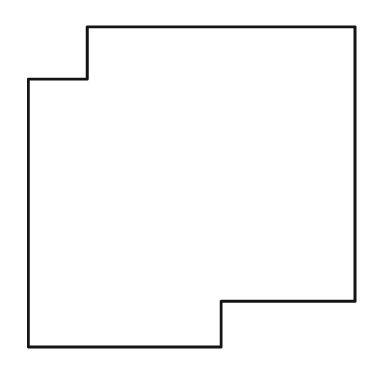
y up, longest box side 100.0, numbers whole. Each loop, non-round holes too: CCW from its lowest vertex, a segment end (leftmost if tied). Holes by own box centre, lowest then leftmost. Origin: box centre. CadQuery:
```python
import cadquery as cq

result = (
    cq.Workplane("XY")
    .moveTo(-50.0, -49.0)
    .lineTo(9.0, -49.0)
    .lineTo(9.0, -35.0)
    .lineTo(50.0, -35.0)
    .lineTo(50.0, 49.0)
    .lineTo(-32.0, 49.0)
    .lineTo(-32.0, 33.0)
    .lineTo(-50.0, 33.0)
    .close()
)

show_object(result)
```